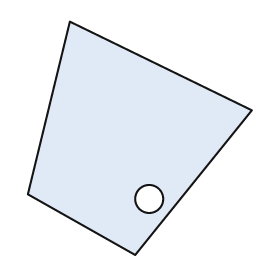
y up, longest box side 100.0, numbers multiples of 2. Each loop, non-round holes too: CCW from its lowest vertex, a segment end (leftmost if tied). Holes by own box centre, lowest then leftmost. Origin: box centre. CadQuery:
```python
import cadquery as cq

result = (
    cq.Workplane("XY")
    .moveTo(-2.0, -50.0)
    .lineTo(48.0, 12.0)
    .lineTo(-30.0, 50.0)
    .lineTo(-48.0, -24.0)
    .close()
    .moveTo(4.0, -26.0)
    .circle(6.0)
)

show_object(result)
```